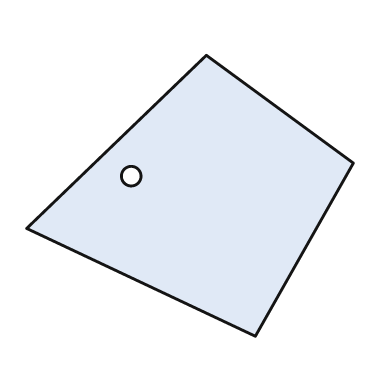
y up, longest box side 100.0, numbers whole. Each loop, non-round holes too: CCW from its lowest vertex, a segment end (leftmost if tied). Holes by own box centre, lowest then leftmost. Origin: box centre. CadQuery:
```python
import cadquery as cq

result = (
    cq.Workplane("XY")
    .moveTo(20.0, -43.0)
    .lineTo(50.0, 10.0)
    .lineTo(5.0, 43.0)
    .lineTo(-50.0, -10.0)
    .close()
    .moveTo(-18.0, 6.0)
    .circle(3.0)
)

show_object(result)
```